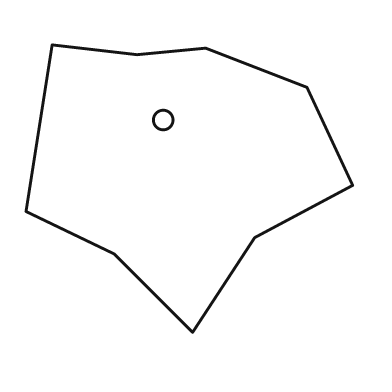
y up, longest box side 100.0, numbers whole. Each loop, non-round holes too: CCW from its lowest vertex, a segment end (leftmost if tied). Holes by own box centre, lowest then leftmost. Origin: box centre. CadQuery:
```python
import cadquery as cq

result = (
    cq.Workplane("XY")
    .moveTo(1.0, -44.0)
    .lineTo(20.0, -15.0)
    .lineTo(50.0, 1.0)
    .lineTo(36.0, 31.0)
    .lineTo(5.0, 43.0)
    .lineTo(-16.0, 41.0)
    .lineTo(-42.0, 44.0)
    .lineTo(-50.0, -7.0)
    .lineTo(-23.0, -20.0)
    .close()
    .moveTo(-8.0, 21.0)
    .circle(3.0)
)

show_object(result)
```